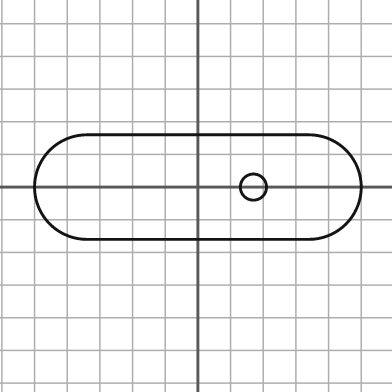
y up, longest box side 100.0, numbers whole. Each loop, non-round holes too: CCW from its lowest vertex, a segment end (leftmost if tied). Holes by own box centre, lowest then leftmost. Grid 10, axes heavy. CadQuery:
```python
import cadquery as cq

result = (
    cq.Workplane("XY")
    .moveTo(-34.0, -16.0)
    .lineTo(34.0, -16.0)
    .threePointArc((50.0, 0.0), (34.0, 16.0))
    .lineTo(-34.0, 16.0)
    .threePointArc((-50.0, 0.0), (-34.0, -16.0))
    .close()
    .moveTo(17.0, 0.0)
    .circle(4.0)
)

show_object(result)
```